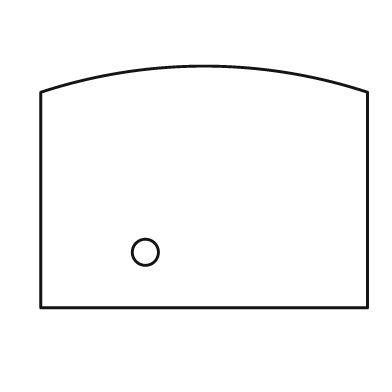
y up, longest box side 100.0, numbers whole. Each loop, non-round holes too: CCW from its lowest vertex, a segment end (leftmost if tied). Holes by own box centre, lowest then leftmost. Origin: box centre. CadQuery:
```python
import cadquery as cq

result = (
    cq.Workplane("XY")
    .moveTo(-50.0, -37.0)
    .lineTo(50.0, -37.0)
    .lineTo(50.0, 29.0)
    .threePointArc((0.0, 37.0), (-50.0, 29.0))
    .close()
    .moveTo(-18.0, -20.0)
    .circle(4.0)
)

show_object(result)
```